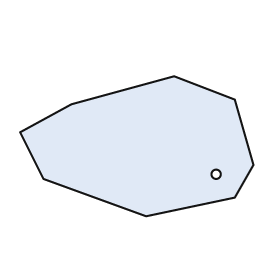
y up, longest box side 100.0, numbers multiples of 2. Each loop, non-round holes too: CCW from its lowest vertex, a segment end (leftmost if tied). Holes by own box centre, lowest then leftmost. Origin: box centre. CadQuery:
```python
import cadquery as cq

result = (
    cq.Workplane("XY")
    .moveTo(4.0, -30.0)
    .lineTo(42.0, -22.0)
    .lineTo(50.0, -8.0)
    .lineTo(42.0, 20.0)
    .lineTo(16.0, 30.0)
    .lineTo(-28.0, 18.0)
    .lineTo(-50.0, 6.0)
    .lineTo(-40.0, -14.0)
    .close()
    .moveTo(34.0, -12.0)
    .circle(2.0)
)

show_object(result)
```